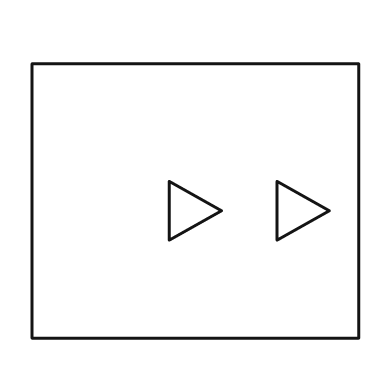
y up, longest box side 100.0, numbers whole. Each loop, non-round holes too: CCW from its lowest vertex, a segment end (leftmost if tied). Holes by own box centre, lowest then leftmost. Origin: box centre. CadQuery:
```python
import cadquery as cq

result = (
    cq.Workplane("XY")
    .moveTo(-50.0, -42.0)
    .lineTo(50.0, -42.0)
    .lineTo(50.0, 42.0)
    .lineTo(-50.0, 42.0)
    .close()
    .moveTo(-8.0, -12.0)
    .lineTo(8.0, -3.0)
    .lineTo(-8.0, 6.0)
    .close()
    .moveTo(25.0, -12.0)
    .lineTo(41.0, -3.0)
    .lineTo(25.0, 6.0)
    .close()
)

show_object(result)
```